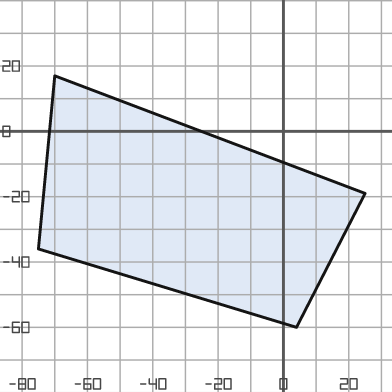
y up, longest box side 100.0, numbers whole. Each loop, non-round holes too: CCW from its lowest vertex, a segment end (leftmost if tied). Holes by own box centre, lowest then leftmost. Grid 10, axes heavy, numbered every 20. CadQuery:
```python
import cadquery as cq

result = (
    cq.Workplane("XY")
    .moveTo(4.0, -60.0)
    .lineTo(25.0, -19.0)
    .lineTo(-70.0, 17.0)
    .lineTo(-75.0, -36.0)
    .close()
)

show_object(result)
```